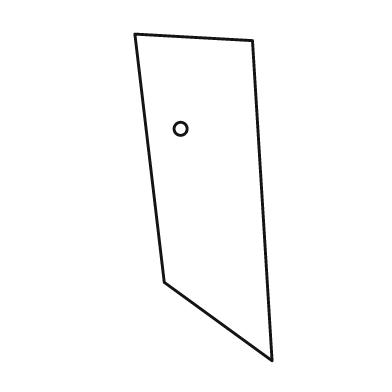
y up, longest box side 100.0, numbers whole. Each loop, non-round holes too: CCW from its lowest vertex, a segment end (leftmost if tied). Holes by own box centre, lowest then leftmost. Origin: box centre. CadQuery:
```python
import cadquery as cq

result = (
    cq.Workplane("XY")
    .moveTo(21.0, -50.0)
    .lineTo(15.0, 48.0)
    .lineTo(-21.0, 50.0)
    .lineTo(-12.0, -26.0)
    .close()
    .moveTo(-7.0, 21.0)
    .circle(2.0)
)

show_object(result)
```